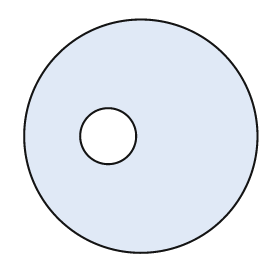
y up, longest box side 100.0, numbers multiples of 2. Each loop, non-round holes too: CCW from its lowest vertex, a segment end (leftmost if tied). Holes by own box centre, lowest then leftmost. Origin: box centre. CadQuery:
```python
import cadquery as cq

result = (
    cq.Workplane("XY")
    .moveTo(0.0, 0.0)
    .circle(50.0)
    .moveTo(-14.0, 0.0)
    .circle(12.0)
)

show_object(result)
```